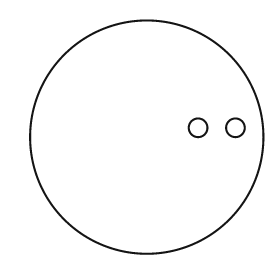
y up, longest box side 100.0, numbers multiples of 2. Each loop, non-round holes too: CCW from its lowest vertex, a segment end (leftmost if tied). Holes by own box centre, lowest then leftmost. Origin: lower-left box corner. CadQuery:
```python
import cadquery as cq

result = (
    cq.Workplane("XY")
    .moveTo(50.0, 50.0)
    .circle(50.0)
    .moveTo(72.0, 54.0)
    .circle(4.0)
    .moveTo(88.0, 54.0)
    .circle(4.0)
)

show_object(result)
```